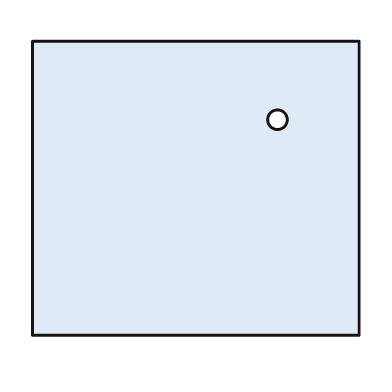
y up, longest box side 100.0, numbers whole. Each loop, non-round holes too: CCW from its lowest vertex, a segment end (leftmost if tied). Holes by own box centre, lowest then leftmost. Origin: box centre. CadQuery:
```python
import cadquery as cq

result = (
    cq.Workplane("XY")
    .moveTo(-50.0, -45.0)
    .lineTo(50.0, -45.0)
    .lineTo(50.0, 45.0)
    .lineTo(-50.0, 45.0)
    .close()
    .moveTo(25.0, 21.0)
    .circle(3.0)
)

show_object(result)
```